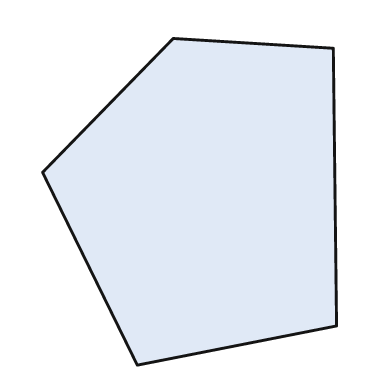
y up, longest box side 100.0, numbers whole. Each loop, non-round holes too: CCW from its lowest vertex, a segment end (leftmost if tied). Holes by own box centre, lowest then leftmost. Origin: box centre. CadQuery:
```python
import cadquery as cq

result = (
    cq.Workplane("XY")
    .moveTo(-16.0, -50.0)
    .lineTo(45.0, -38.0)
    .lineTo(44.0, 47.0)
    .lineTo(-5.0, 50.0)
    .lineTo(-45.0, 9.0)
    .close()
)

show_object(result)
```